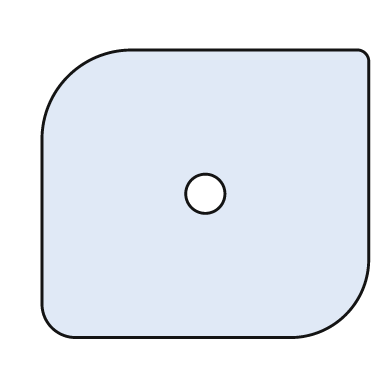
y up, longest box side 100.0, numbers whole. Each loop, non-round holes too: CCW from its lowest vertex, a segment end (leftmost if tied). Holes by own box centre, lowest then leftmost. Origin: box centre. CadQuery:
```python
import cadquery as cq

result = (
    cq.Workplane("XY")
    .moveTo(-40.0, -44.0)
    .lineTo(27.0, -44.0)
    .threePointArc((43.0, -37.0), (50.0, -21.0))
    .lineTo(50.0, 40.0)
    .threePointArc((49.0, 43.0), (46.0, 44.0))
    .lineTo(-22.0, 44.0)
    .threePointArc((-42.0, 36.0), (-50.0, 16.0))
    .lineTo(-50.0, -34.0)
    .threePointArc((-47.0, -41.0), (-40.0, -44.0))
    .close()
    .moveTo(0.0, 0.0)
    .circle(6.0)
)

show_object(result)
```